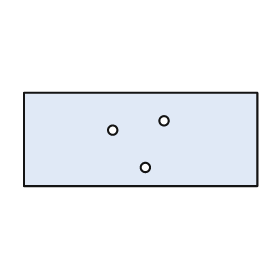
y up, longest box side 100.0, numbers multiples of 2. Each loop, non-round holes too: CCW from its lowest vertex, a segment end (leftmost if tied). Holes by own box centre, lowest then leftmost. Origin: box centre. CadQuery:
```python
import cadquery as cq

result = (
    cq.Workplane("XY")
    .moveTo(-50.0, -20.0)
    .lineTo(50.0, -20.0)
    .lineTo(50.0, 20.0)
    .lineTo(-50.0, 20.0)
    .close()
    .moveTo(2.0, -12.0)
    .circle(2.0)
    .moveTo(-12.0, 4.0)
    .circle(2.0)
    .moveTo(10.0, 8.0)
    .circle(2.0)
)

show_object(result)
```